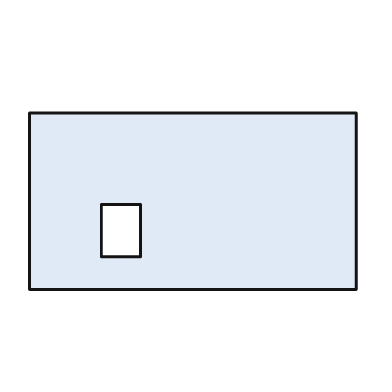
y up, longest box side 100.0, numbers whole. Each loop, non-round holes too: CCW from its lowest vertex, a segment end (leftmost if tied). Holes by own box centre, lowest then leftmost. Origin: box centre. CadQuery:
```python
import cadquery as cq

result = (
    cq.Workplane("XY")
    .moveTo(-50.0, -27.0)
    .lineTo(50.0, -27.0)
    .lineTo(50.0, 27.0)
    .lineTo(-50.0, 27.0)
    .close()
    .moveTo(-28.0, -17.0)
    .lineTo(-16.0, -17.0)
    .lineTo(-16.0, -1.0)
    .lineTo(-28.0, -1.0)
    .close()
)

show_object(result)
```